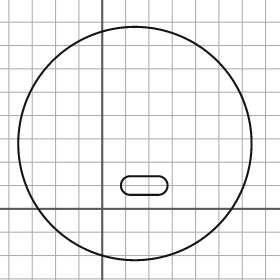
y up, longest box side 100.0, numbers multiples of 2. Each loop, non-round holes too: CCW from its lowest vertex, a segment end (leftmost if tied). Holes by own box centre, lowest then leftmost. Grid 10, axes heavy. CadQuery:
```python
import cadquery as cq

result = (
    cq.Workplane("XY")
    .moveTo(14.0, 28.0)
    .circle(50.0)
    .moveTo(12.0, 6.0)
    .lineTo(24.0, 6.0)
    .threePointArc((28.0, 10.0), (24.0, 14.0))
    .lineTo(12.0, 14.0)
    .threePointArc((8.0, 10.0), (12.0, 6.0))
    .close()
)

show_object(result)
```